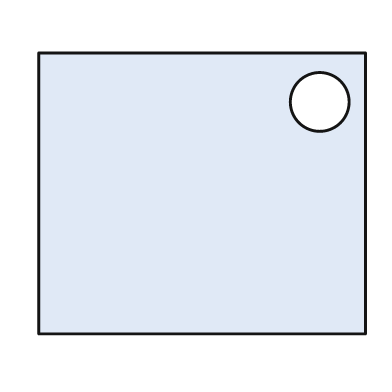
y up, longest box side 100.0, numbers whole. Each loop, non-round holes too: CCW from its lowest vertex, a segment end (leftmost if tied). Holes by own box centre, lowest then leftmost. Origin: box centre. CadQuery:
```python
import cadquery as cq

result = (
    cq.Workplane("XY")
    .moveTo(-50.0, -43.0)
    .lineTo(50.0, -43.0)
    .lineTo(50.0, 43.0)
    .lineTo(-50.0, 43.0)
    .close()
    .moveTo(36.0, 28.0)
    .circle(9.0)
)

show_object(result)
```